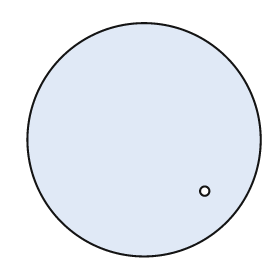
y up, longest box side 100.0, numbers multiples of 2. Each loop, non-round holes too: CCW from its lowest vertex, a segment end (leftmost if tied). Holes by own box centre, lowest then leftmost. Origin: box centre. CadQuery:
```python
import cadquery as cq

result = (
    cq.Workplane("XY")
    .moveTo(0.0, 0.0)
    .circle(50.0)
    .moveTo(26.0, -22.0)
    .circle(2.0)
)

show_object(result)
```